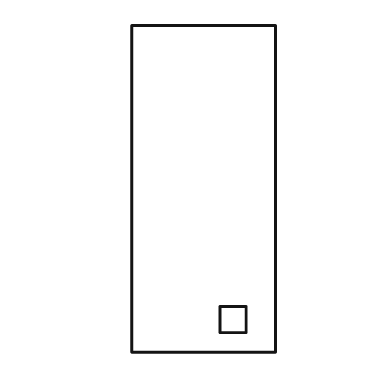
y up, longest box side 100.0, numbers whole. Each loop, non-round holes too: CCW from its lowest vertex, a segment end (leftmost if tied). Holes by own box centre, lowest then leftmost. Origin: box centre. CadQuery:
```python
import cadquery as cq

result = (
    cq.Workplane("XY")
    .moveTo(-22.0, -50.0)
    .lineTo(22.0, -50.0)
    .lineTo(22.0, 50.0)
    .lineTo(-22.0, 50.0)
    .close()
    .moveTo(5.0, -44.0)
    .lineTo(13.0, -44.0)
    .lineTo(13.0, -36.0)
    .lineTo(5.0, -36.0)
    .close()
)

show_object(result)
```